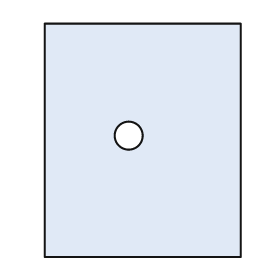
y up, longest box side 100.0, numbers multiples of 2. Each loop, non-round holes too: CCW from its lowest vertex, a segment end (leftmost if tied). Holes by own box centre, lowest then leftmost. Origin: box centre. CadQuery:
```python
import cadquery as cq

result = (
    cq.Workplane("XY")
    .moveTo(-42.0, -50.0)
    .lineTo(42.0, -50.0)
    .lineTo(42.0, 50.0)
    .lineTo(-42.0, 50.0)
    .close()
    .moveTo(-6.0, 2.0)
    .circle(6.0)
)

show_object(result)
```